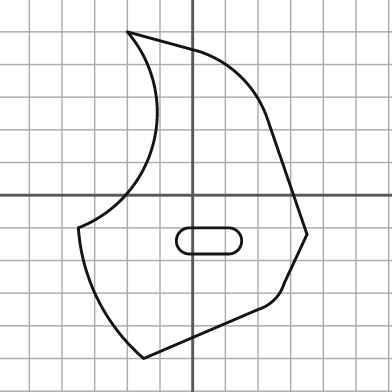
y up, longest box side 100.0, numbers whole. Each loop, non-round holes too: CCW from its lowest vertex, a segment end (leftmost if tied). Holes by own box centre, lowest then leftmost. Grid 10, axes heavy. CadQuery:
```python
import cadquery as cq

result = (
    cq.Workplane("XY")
    .moveTo(-15.0, -50.0)
    .lineTo(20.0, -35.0)
    .threePointArc((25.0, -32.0), (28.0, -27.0))
    .lineTo(35.0, -12.0)
    .lineTo(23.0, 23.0)
    .threePointArc((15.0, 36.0), (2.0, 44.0))
    .lineTo(-20.0, 50.0)
    .threePointArc((-12.0, 16.0), (-35.0, -10.0))
    .threePointArc((-29.0, -32.0), (-15.0, -50.0))
    .close()
    .moveTo(-1.0, -18.0)
    .lineTo(11.0, -18.0)
    .threePointArc((15.0, -14.0), (11.0, -10.0))
    .lineTo(-1.0, -10.0)
    .threePointArc((-5.0, -14.0), (-1.0, -18.0))
    .close()
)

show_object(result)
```